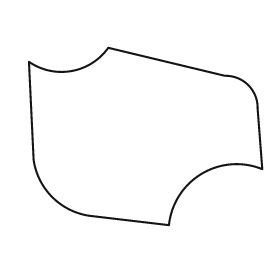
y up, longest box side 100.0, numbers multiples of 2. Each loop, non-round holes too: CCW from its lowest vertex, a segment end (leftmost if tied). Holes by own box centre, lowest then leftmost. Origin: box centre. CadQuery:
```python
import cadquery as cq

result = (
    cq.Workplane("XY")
    .moveTo(10.0, -38.0)
    .threePointArc((24.0, -16.0), (50.0, -14.0))
    .lineTo(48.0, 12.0)
    .threePointArc((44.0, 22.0), (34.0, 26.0))
    .lineTo(-16.0, 38.0)
    .threePointArc((-32.0, 28.0), (-50.0, 32.0))
    .lineTo(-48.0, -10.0)
    .threePointArc((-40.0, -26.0), (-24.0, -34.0))
    .close()
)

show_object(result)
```